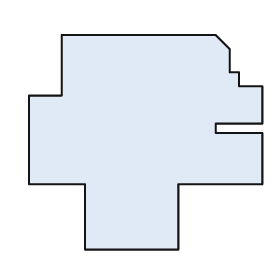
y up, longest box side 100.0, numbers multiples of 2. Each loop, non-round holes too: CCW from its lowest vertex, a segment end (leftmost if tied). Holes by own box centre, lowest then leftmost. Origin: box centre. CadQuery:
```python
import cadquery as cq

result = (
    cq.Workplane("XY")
    .moveTo(-26.0, -46.0)
    .lineTo(14.0, -46.0)
    .lineTo(14.0, -18.0)
    .lineTo(50.0, -18.0)
    .lineTo(50.0, 4.0)
    .lineTo(30.0, 4.0)
    .lineTo(30.0, 8.0)
    .lineTo(50.0, 8.0)
    .lineTo(50.0, 24.0)
    .lineTo(40.0, 24.0)
    .lineTo(40.0, 30.0)
    .lineTo(36.0, 30.0)
    .lineTo(36.0, 40.0)
    .lineTo(30.0, 46.0)
    .lineTo(-36.0, 46.0)
    .lineTo(-36.0, 20.0)
    .lineTo(-50.0, 20.0)
    .lineTo(-50.0, -18.0)
    .lineTo(-26.0, -18.0)
    .close()
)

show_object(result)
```